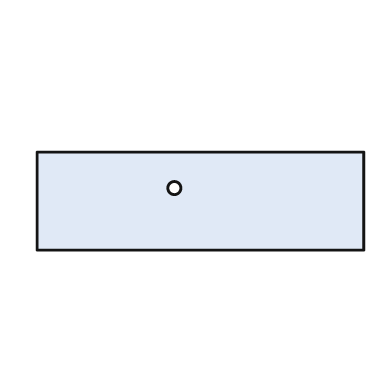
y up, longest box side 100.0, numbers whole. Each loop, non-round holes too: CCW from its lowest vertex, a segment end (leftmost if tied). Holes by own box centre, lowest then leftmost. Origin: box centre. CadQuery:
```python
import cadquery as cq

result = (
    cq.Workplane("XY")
    .moveTo(-50.0, -15.0)
    .lineTo(50.0, -15.0)
    .lineTo(50.0, 15.0)
    .lineTo(-50.0, 15.0)
    .close()
    .moveTo(-8.0, 4.0)
    .circle(2.0)
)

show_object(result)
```